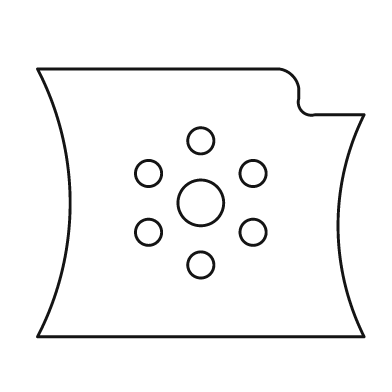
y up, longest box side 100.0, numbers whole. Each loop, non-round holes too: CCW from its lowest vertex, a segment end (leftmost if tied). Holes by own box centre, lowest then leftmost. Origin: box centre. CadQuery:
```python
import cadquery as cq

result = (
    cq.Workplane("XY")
    .moveTo(-50.0, -41.0)
    .lineTo(50.0, -41.0)
    .threePointArc((42.0, -7.0), (50.0, 27.0))
    .lineTo(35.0, 27.0)
    .threePointArc((31.0, 28.0), (30.0, 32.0))
    .lineTo(30.0, 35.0)
    .threePointArc((28.0, 39.0), (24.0, 41.0))
    .lineTo(-50.0, 41.0)
    .threePointArc((-40.0, 0.0), (-50.0, -41.0))
    .close()
    .moveTo(0.0, -19.0)
    .circle(4.0)
    .moveTo(-16.0, -9.0)
    .circle(4.0)
    .moveTo(16.0, -9.0)
    .circle(4.0)
    .moveTo(0.0, 0.0)
    .circle(7.0)
    .moveTo(-16.0, 9.0)
    .circle(4.0)
    .moveTo(16.0, 9.0)
    .circle(4.0)
    .moveTo(0.0, 19.0)
    .circle(4.0)
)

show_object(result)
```